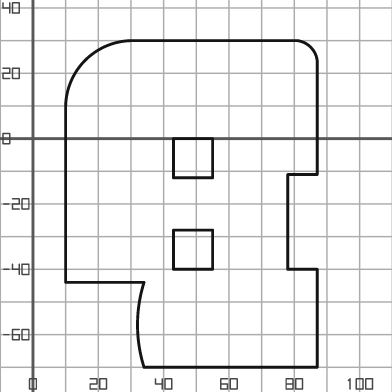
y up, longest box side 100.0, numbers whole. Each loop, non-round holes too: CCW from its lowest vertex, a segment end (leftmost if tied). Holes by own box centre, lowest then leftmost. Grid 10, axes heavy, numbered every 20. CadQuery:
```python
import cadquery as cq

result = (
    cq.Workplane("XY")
    .moveTo(34.0, -70.0)
    .lineTo(87.0, -70.0)
    .lineTo(87.0, -40.0)
    .lineTo(78.0, -40.0)
    .lineTo(78.0, -11.0)
    .lineTo(87.0, -11.0)
    .lineTo(87.0, 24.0)
    .threePointArc((85.0, 28.0), (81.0, 30.0))
    .lineTo(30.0, 30.0)
    .threePointArc((16.0, 24.0), (10.0, 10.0))
    .lineTo(10.0, -44.0)
    .lineTo(34.0, -44.0)
    .threePointArc((32.0, -57.0), (34.0, -70.0))
    .close()
    .moveTo(43.0, -40.0)
    .lineTo(55.0, -40.0)
    .lineTo(55.0, -28.0)
    .lineTo(43.0, -28.0)
    .close()
    .moveTo(43.0, -12.0)
    .lineTo(55.0, -12.0)
    .lineTo(55.0, 0.0)
    .lineTo(43.0, 0.0)
    .close()
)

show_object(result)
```